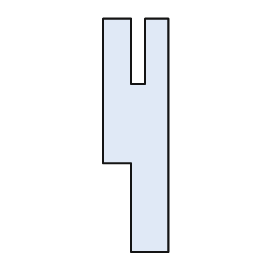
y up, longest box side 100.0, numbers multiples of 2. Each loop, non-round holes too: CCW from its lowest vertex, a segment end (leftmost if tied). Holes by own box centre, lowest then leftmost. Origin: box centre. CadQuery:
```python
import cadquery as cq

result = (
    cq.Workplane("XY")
    .moveTo(-2.0, -50.0)
    .lineTo(14.0, -50.0)
    .lineTo(14.0, 50.0)
    .lineTo(4.0, 50.0)
    .lineTo(4.0, 22.0)
    .lineTo(-2.0, 22.0)
    .lineTo(-2.0, 50.0)
    .lineTo(-14.0, 50.0)
    .lineTo(-14.0, -12.0)
    .lineTo(-2.0, -12.0)
    .close()
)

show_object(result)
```